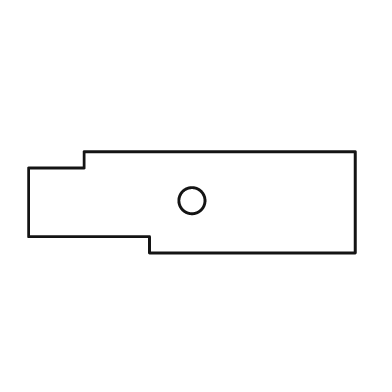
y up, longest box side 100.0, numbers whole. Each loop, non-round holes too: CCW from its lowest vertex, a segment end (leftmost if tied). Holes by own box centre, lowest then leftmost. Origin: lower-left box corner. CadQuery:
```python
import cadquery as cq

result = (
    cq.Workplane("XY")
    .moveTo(37.0, 0.0)
    .lineTo(100.0, 0.0)
    .lineTo(100.0, 31.0)
    .lineTo(17.0, 31.0)
    .lineTo(17.0, 26.0)
    .lineTo(0.0, 26.0)
    .lineTo(0.0, 5.0)
    .lineTo(37.0, 5.0)
    .close()
    .moveTo(50.0, 16.0)
    .circle(4.0)
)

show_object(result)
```